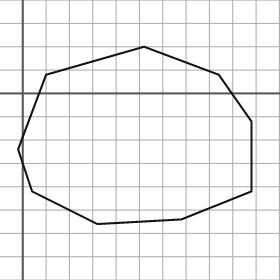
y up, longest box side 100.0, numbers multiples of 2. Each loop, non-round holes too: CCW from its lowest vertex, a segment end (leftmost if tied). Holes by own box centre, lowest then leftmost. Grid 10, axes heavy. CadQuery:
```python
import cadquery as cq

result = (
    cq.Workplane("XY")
    .moveTo(32.0, -56.0)
    .lineTo(68.0, -54.0)
    .lineTo(98.0, -42.0)
    .lineTo(98.0, -12.0)
    .lineTo(84.0, 8.0)
    .lineTo(52.0, 20.0)
    .lineTo(10.0, 8.0)
    .lineTo(-2.0, -24.0)
    .lineTo(4.0, -42.0)
    .close()
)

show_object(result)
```